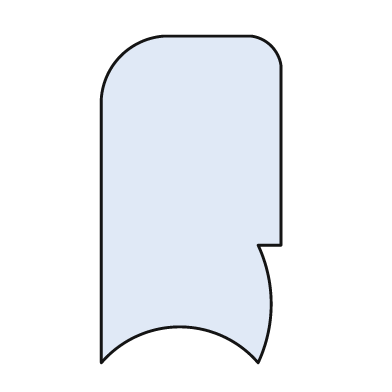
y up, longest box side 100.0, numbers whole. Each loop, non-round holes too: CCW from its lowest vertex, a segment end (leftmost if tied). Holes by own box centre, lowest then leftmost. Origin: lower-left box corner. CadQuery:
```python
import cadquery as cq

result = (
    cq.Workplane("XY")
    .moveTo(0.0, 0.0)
    .threePointArc((24.0, 11.0), (48.0, 0.0))
    .threePointArc((52.0, 18.0), (48.0, 36.0))
    .lineTo(55.0, 36.0)
    .lineTo(55.0, 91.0)
    .threePointArc((52.0, 97.0), (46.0, 100.0))
    .lineTo(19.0, 100.0)
    .threePointArc((6.0, 94.0), (0.0, 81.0))
    .close()
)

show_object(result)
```